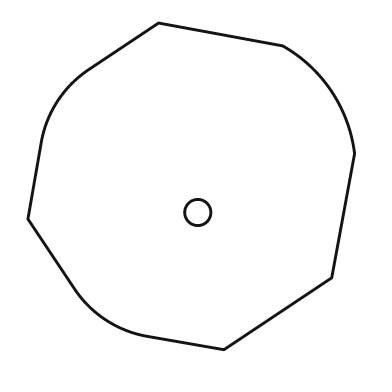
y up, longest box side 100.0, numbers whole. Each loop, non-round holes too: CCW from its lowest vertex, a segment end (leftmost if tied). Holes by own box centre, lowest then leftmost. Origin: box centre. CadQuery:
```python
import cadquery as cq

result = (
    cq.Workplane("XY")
    .moveTo(10.0, -50.0)
    .lineTo(43.0, -28.0)
    .lineTo(50.0, 10.0)
    .threePointArc((43.0, 29.0), (28.0, 43.0))
    .lineTo(-10.0, 50.0)
    .lineTo(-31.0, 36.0)
    .threePointArc((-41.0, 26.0), (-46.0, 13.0))
    .lineTo(-50.0, -10.0)
    .lineTo(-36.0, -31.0)
    .threePointArc((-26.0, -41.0), (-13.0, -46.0))
    .close()
    .moveTo(2.0, -8.0)
    .circle(4.0)
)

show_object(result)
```